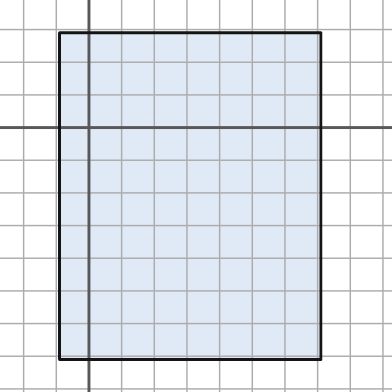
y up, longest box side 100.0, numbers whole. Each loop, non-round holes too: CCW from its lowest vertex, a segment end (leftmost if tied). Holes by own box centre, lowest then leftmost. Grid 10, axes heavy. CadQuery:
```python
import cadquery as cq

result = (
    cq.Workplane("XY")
    .moveTo(-9.0, -71.0)
    .lineTo(71.0, -71.0)
    .lineTo(71.0, 29.0)
    .lineTo(-9.0, 29.0)
    .close()
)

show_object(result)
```